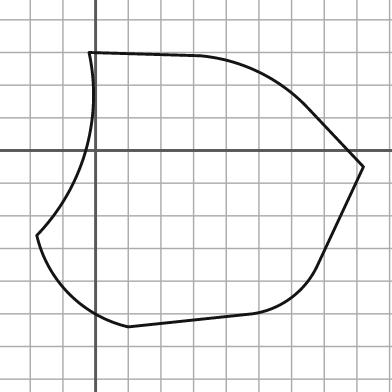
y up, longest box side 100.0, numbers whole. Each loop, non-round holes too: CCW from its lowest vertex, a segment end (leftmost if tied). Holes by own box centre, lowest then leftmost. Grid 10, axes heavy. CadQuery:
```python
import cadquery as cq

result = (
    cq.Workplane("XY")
    .moveTo(10.0, -54.0)
    .lineTo(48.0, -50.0)
    .threePointArc((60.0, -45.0), (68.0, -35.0))
    .lineTo(82.0, -5.0)
    .lineTo(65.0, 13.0)
    .threePointArc((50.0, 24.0), (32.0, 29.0))
    .lineTo(-2.0, 30.0)
    .threePointArc((-3.0, 0.0), (-18.0, -26.0))
    .threePointArc((-8.0, -44.0), (10.0, -54.0))
    .close()
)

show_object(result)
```